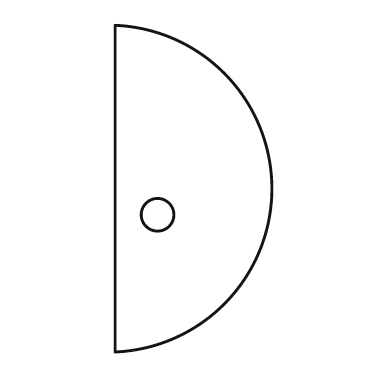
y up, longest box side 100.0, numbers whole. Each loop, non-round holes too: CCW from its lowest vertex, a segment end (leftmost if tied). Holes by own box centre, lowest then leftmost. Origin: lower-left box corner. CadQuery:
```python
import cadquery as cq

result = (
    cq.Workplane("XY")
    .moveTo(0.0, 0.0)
    .threePointArc((48.0, 50.0), (0.0, 100.0))
    .close()
    .moveTo(13.0, 42.0)
    .circle(5.0)
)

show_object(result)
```